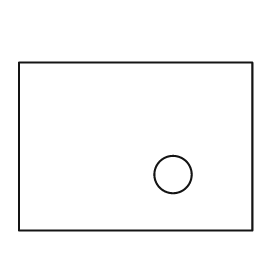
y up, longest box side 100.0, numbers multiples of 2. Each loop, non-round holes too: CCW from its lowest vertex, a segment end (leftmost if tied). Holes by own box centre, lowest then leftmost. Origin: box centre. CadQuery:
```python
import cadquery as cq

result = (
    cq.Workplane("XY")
    .moveTo(-50.0, -36.0)
    .lineTo(50.0, -36.0)
    .lineTo(50.0, 36.0)
    .lineTo(-50.0, 36.0)
    .close()
    .moveTo(16.0, -12.0)
    .circle(8.0)
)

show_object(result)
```